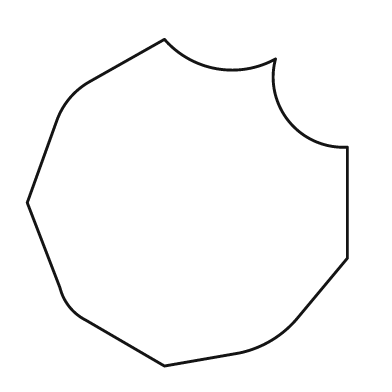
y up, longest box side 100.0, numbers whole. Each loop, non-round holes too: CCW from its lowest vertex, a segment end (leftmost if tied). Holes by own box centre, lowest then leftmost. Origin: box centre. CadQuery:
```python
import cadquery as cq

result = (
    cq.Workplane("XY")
    .moveTo(-7.0, -50.0)
    .lineTo(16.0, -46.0)
    .threePointArc((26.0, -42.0), (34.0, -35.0))
    .lineTo(49.0, -17.0)
    .lineTo(49.0, 17.0)
    .threePointArc((31.0, 25.0), (27.0, 44.0))
    .threePointArc((9.0, 41.0), (-7.0, 50.0))
    .lineTo(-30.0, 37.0)
    .threePointArc((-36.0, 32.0), (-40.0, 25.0))
    .lineTo(-49.0, 0.0)
    .lineTo(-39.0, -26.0)
    .threePointArc((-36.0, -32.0), (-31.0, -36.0))
    .close()
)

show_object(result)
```